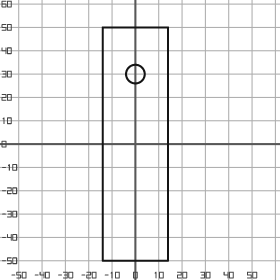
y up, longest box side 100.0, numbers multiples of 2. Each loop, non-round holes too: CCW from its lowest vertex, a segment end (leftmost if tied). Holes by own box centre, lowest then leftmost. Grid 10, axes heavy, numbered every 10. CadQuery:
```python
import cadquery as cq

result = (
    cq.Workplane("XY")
    .moveTo(-14.0, -50.0)
    .lineTo(14.0, -50.0)
    .lineTo(14.0, 50.0)
    .lineTo(-14.0, 50.0)
    .close()
    .moveTo(0.0, 30.0)
    .circle(4.0)
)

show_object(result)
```